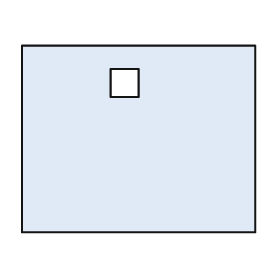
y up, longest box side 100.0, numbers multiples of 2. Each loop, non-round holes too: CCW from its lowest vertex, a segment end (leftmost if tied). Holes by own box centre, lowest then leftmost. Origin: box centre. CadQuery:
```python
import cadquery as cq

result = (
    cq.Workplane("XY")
    .moveTo(-50.0, -40.0)
    .lineTo(50.0, -40.0)
    .lineTo(50.0, 40.0)
    .lineTo(-50.0, 40.0)
    .close()
    .moveTo(-12.0, 18.0)
    .lineTo(0.0, 18.0)
    .lineTo(0.0, 30.0)
    .lineTo(-12.0, 30.0)
    .close()
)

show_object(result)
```